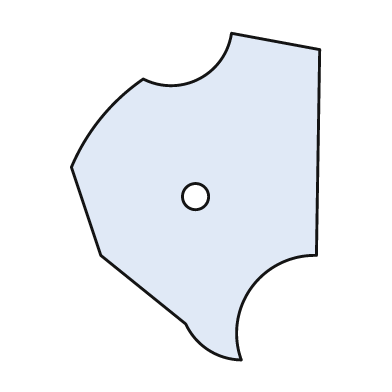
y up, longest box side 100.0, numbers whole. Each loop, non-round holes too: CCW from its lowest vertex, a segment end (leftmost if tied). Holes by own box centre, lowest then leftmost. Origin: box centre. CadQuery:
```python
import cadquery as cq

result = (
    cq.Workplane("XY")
    .moveTo(14.0, -50.0)
    .threePointArc((17.0, -28.0), (37.0, -18.0))
    .lineTo(38.0, 45.0)
    .lineTo(11.0, 50.0)
    .threePointArc((1.0, 36.0), (-16.0, 36.0))
    .threePointArc((-29.0, 24.0), (-38.0, 9.0))
    .lineTo(-29.0, -18.0)
    .lineTo(-3.0, -39.0)
    .threePointArc((4.0, -47.0), (14.0, -50.0))
    .close()
    .moveTo(0.0, 0.0)
    .circle(4.0)
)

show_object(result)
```